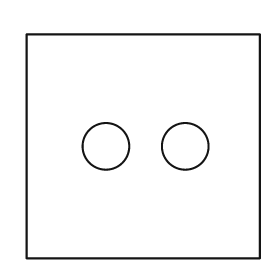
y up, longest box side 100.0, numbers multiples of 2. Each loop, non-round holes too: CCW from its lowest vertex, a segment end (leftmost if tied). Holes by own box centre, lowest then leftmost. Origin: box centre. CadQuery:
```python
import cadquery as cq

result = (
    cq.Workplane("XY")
    .moveTo(-50.0, -48.0)
    .lineTo(50.0, -48.0)
    .lineTo(50.0, 48.0)
    .lineTo(-50.0, 48.0)
    .close()
    .moveTo(-16.0, 0.0)
    .circle(10.0)
    .moveTo(18.0, 0.0)
    .circle(10.0)
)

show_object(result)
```